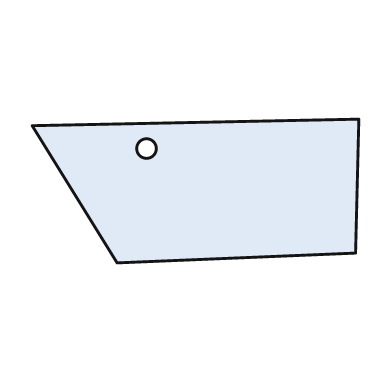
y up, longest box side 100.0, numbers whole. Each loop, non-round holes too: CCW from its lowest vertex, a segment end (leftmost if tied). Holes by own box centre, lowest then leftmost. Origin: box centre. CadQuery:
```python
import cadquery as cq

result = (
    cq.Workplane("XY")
    .moveTo(-24.0, -22.0)
    .lineTo(49.0, -19.0)
    .lineTo(50.0, 22.0)
    .lineTo(-50.0, 20.0)
    .close()
    .moveTo(-15.0, 13.0)
    .circle(3.0)
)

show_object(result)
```